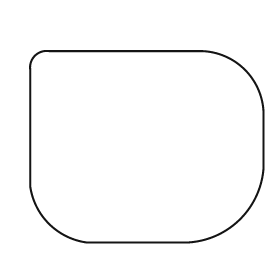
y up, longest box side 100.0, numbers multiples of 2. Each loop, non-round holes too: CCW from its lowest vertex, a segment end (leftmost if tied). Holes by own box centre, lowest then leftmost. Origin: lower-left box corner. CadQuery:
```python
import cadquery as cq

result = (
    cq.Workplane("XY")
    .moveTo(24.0, 0.0)
    .lineTo(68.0, 0.0)
    .threePointArc((90.0, 10.0), (100.0, 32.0))
    .lineTo(100.0, 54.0)
    .threePointArc((92.0, 74.0), (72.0, 82.0))
    .lineTo(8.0, 82.0)
    .threePointArc((2.0, 80.0), (0.0, 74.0))
    .lineTo(0.0, 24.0)
    .threePointArc((8.0, 8.0), (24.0, 0.0))
    .close()
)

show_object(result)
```